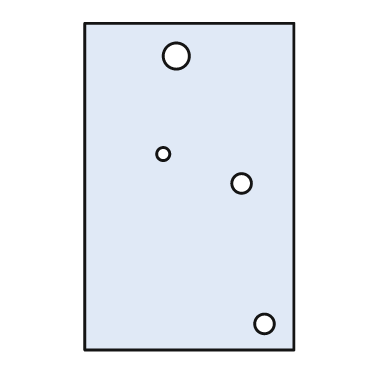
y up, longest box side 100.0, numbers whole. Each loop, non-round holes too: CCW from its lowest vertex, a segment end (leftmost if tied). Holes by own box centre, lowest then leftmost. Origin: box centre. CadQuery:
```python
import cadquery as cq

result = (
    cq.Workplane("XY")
    .moveTo(-32.0, -50.0)
    .lineTo(32.0, -50.0)
    .lineTo(32.0, 50.0)
    .lineTo(-32.0, 50.0)
    .close()
    .moveTo(23.0, -42.0)
    .circle(3.0)
    .moveTo(16.0, 1.0)
    .circle(3.0)
    .moveTo(-8.0, 10.0)
    .circle(2.0)
    .moveTo(-4.0, 40.0)
    .circle(4.0)
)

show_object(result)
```